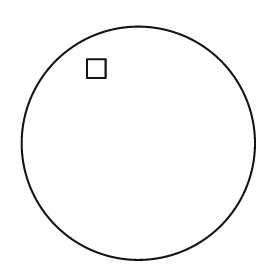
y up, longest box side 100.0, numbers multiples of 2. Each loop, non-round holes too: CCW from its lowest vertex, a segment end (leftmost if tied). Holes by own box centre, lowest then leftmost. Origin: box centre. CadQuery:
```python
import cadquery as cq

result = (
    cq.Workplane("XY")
    .moveTo(0.0, 0.0)
    .circle(50.0)
    .moveTo(-22.0, 28.0)
    .lineTo(-14.0, 28.0)
    .lineTo(-14.0, 36.0)
    .lineTo(-22.0, 36.0)
    .close()
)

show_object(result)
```